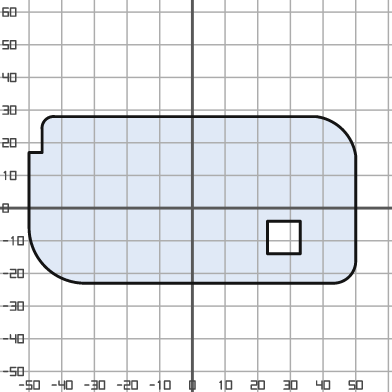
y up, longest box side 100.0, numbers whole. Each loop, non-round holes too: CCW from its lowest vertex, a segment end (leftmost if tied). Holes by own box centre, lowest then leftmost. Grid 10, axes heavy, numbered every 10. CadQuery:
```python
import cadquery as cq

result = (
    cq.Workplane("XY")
    .moveTo(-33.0, -23.0)
    .lineTo(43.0, -23.0)
    .threePointArc((48.0, -21.0), (50.0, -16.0))
    .lineTo(50.0, 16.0)
    .threePointArc((46.0, 24.0), (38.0, 28.0))
    .lineTo(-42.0, 28.0)
    .threePointArc((-45.0, 27.0), (-46.0, 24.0))
    .lineTo(-46.0, 17.0)
    .lineTo(-50.0, 17.0)
    .lineTo(-50.0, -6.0)
    .threePointArc((-45.0, -18.0), (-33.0, -23.0))
    .close()
    .moveTo(23.0, -14.0)
    .lineTo(33.0, -14.0)
    .lineTo(33.0, -4.0)
    .lineTo(23.0, -4.0)
    .close()
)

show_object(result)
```